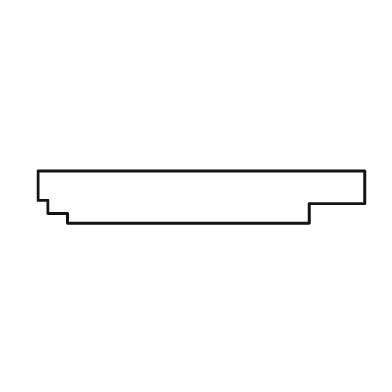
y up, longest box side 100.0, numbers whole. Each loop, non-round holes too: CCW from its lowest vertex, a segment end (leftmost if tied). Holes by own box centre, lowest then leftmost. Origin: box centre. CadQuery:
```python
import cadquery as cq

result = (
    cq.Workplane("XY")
    .moveTo(-41.0, -8.0)
    .lineTo(33.0, -8.0)
    .lineTo(33.0, -2.0)
    .lineTo(50.0, -2.0)
    .lineTo(50.0, 8.0)
    .lineTo(-50.0, 8.0)
    .lineTo(-50.0, -1.0)
    .lineTo(-47.0, -1.0)
    .lineTo(-47.0, -5.0)
    .lineTo(-41.0, -5.0)
    .close()
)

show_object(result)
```